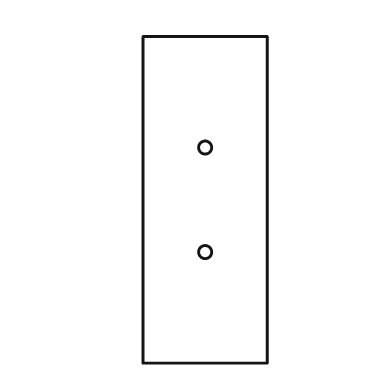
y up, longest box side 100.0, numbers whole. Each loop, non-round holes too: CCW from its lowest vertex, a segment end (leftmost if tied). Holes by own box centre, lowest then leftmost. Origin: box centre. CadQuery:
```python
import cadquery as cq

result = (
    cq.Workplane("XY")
    .moveTo(-19.0, -50.0)
    .lineTo(19.0, -50.0)
    .lineTo(19.0, 50.0)
    .lineTo(-19.0, 50.0)
    .close()
    .moveTo(0.0, -16.0)
    .circle(2.0)
    .moveTo(0.0, 16.0)
    .circle(2.0)
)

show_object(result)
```